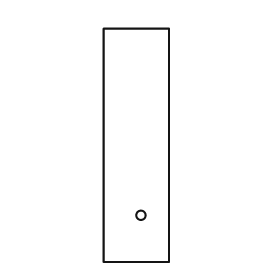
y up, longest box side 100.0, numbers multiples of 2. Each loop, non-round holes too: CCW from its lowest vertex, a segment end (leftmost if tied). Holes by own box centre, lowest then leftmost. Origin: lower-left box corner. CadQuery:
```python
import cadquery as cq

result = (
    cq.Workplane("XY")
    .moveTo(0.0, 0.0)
    .lineTo(28.0, 0.0)
    .lineTo(28.0, 100.0)
    .lineTo(0.0, 100.0)
    .close()
    .moveTo(16.0, 20.0)
    .circle(2.0)
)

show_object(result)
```